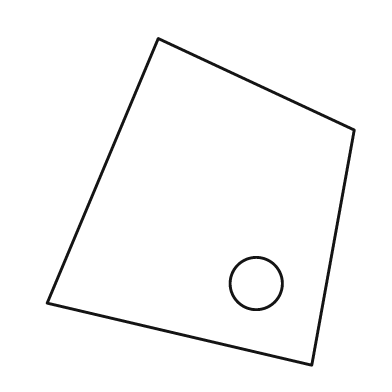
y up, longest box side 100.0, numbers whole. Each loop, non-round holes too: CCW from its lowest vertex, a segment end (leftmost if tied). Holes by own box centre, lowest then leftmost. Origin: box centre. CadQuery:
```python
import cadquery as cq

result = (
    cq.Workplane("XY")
    .moveTo(34.0, -50.0)
    .lineTo(47.0, 22.0)
    .lineTo(-13.0, 50.0)
    .lineTo(-47.0, -31.0)
    .close()
    .moveTo(17.0, -25.0)
    .circle(8.0)
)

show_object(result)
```